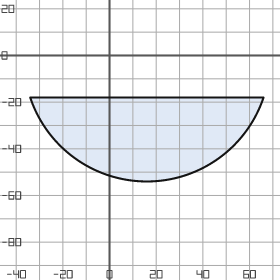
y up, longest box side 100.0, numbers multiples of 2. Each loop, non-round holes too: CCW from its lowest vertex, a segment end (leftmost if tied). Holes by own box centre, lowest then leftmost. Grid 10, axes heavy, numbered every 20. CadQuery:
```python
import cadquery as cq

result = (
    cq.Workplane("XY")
    .moveTo(-34.0, -18.0)
    .threePointArc((16.0, -54.0), (66.0, -18.0))
    .close()
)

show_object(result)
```